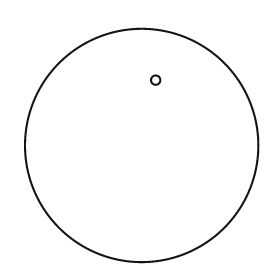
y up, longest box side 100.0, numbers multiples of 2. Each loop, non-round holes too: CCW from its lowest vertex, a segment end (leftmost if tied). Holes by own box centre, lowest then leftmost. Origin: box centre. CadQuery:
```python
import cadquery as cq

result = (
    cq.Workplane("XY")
    .moveTo(0.0, 0.0)
    .circle(50.0)
    .moveTo(6.0, 28.0)
    .circle(2.0)
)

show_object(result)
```